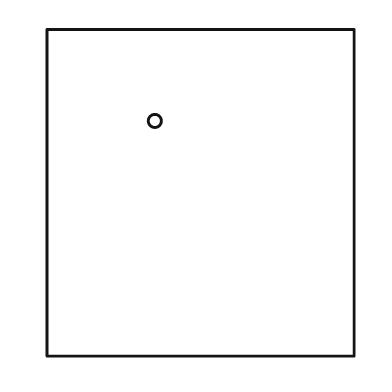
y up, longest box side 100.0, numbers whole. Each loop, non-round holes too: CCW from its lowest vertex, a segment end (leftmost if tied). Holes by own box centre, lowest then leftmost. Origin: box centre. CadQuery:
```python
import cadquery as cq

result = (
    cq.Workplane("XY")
    .moveTo(-47.0, -50.0)
    .lineTo(47.0, -50.0)
    .lineTo(47.0, 50.0)
    .lineTo(-47.0, 50.0)
    .close()
    .moveTo(-14.0, 22.0)
    .circle(2.0)
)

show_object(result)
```